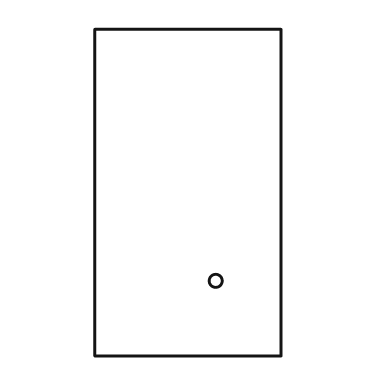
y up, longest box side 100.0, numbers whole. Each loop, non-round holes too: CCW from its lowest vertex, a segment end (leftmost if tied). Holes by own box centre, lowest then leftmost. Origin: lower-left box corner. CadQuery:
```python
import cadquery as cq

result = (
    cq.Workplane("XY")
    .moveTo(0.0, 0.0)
    .lineTo(57.0, 0.0)
    .lineTo(57.0, 100.0)
    .lineTo(0.0, 100.0)
    .close()
    .moveTo(37.0, 23.0)
    .circle(2.0)
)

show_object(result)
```